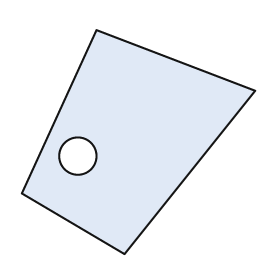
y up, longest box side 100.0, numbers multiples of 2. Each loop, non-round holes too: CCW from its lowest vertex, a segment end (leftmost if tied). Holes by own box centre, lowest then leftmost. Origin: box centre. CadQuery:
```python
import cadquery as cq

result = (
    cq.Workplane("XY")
    .moveTo(-6.0, -48.0)
    .lineTo(50.0, 22.0)
    .lineTo(-18.0, 48.0)
    .lineTo(-50.0, -22.0)
    .close()
    .moveTo(-26.0, -6.0)
    .circle(8.0)
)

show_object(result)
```